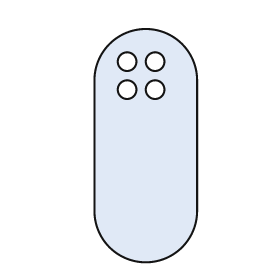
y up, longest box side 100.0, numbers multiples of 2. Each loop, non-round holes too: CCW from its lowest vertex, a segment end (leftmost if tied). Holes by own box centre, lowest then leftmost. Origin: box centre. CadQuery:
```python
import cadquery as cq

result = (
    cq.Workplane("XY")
    .moveTo(-22.0, -28.0)
    .threePointArc((0.0, -50.0), (22.0, -28.0))
    .lineTo(22.0, 28.0)
    .threePointArc((0.0, 50.0), (-22.0, 28.0))
    .close()
    .moveTo(-8.0, 24.0)
    .circle(4.0)
    .moveTo(4.0, 24.0)
    .circle(4.0)
    .moveTo(-8.0, 36.0)
    .circle(4.0)
    .moveTo(4.0, 36.0)
    .circle(4.0)
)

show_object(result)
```